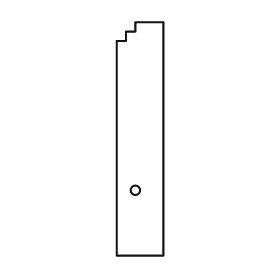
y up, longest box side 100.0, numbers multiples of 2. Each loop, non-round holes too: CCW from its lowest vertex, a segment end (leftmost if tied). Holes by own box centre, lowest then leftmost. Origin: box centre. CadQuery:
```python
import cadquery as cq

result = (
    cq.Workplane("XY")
    .moveTo(-10.0, -50.0)
    .lineTo(10.0, -50.0)
    .lineTo(10.0, 50.0)
    .lineTo(-2.0, 50.0)
    .lineTo(-2.0, 46.0)
    .lineTo(-6.0, 46.0)
    .lineTo(-6.0, 42.0)
    .lineTo(-10.0, 42.0)
    .close()
    .moveTo(-2.0, -22.0)
    .circle(2.0)
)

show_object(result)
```